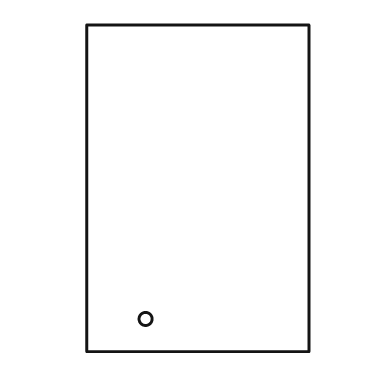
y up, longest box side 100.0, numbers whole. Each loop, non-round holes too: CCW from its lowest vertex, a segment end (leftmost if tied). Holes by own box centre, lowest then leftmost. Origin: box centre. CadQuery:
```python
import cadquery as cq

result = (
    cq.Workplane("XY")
    .moveTo(-34.0, -50.0)
    .lineTo(34.0, -50.0)
    .lineTo(34.0, 50.0)
    .lineTo(-34.0, 50.0)
    .close()
    .moveTo(-16.0, -40.0)
    .circle(2.0)
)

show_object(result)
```